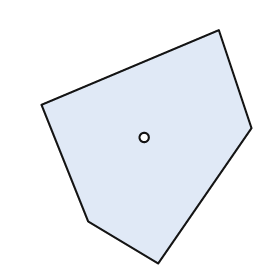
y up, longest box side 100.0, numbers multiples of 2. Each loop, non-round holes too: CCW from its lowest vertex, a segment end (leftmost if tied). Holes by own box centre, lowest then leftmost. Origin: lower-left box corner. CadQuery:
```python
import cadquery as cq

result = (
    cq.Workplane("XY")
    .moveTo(50.0, 0.0)
    .lineTo(90.0, 58.0)
    .lineTo(76.0, 100.0)
    .lineTo(0.0, 68.0)
    .lineTo(20.0, 18.0)
    .close()
    .moveTo(44.0, 54.0)
    .circle(2.0)
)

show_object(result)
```